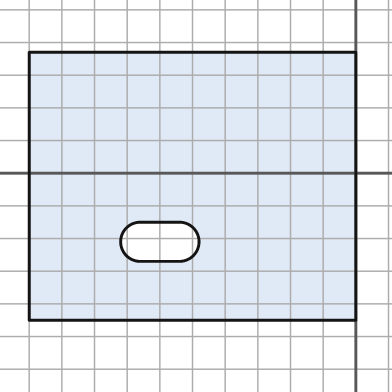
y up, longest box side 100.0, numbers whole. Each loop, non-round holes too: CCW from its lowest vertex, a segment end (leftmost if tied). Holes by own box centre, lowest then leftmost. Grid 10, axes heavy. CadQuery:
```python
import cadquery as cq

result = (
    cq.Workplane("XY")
    .moveTo(-100.0, -45.0)
    .lineTo(0.0, -45.0)
    .lineTo(0.0, 37.0)
    .lineTo(-100.0, 37.0)
    .close()
    .moveTo(-66.0, -27.0)
    .lineTo(-54.0, -27.0)
    .threePointArc((-48.0, -21.0), (-54.0, -15.0))
    .lineTo(-66.0, -15.0)
    .threePointArc((-72.0, -21.0), (-66.0, -27.0))
    .close()
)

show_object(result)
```